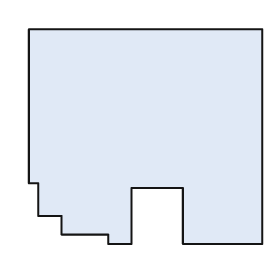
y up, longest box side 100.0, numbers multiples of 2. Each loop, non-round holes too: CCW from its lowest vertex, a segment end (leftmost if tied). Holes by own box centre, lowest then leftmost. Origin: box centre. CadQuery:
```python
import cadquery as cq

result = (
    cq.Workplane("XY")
    .moveTo(-16.0, -46.0)
    .lineTo(-6.0, -46.0)
    .lineTo(-6.0, -22.0)
    .lineTo(16.0, -22.0)
    .lineTo(16.0, -46.0)
    .lineTo(50.0, -46.0)
    .lineTo(50.0, 46.0)
    .lineTo(-50.0, 46.0)
    .lineTo(-50.0, -20.0)
    .lineTo(-46.0, -20.0)
    .lineTo(-46.0, -34.0)
    .lineTo(-36.0, -34.0)
    .lineTo(-36.0, -42.0)
    .lineTo(-16.0, -42.0)
    .close()
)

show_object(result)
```